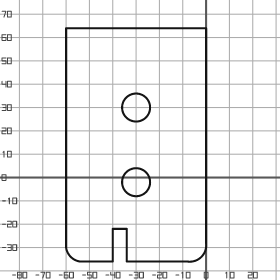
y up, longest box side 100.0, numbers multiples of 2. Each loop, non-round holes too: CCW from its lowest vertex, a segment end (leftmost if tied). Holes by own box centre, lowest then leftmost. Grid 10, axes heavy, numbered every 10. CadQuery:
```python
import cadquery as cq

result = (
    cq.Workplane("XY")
    .moveTo(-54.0, -36.0)
    .lineTo(-40.0, -36.0)
    .lineTo(-40.0, -22.0)
    .lineTo(-34.0, -22.0)
    .lineTo(-34.0, -36.0)
    .lineTo(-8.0, -36.0)
    .threePointArc((-2.0, -34.0), (0.0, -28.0))
    .lineTo(0.0, 64.0)
    .lineTo(-60.0, 64.0)
    .lineTo(-60.0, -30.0)
    .threePointArc((-58.0, -34.0), (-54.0, -36.0))
    .close()
    .moveTo(-30.0, -2.0)
    .circle(6.0)
    .moveTo(-30.0, 30.0)
    .circle(6.0)
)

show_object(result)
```